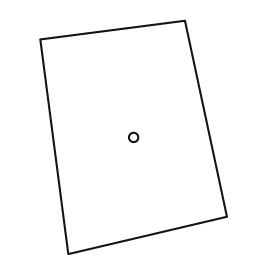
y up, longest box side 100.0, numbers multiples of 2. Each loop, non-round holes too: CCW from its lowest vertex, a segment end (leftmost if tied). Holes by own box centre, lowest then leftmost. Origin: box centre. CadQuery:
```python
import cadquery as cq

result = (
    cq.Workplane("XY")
    .moveTo(-28.0, -50.0)
    .lineTo(40.0, -34.0)
    .lineTo(22.0, 50.0)
    .lineTo(-40.0, 42.0)
    .close()
    .moveTo(0.0, 0.0)
    .circle(2.0)
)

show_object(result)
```